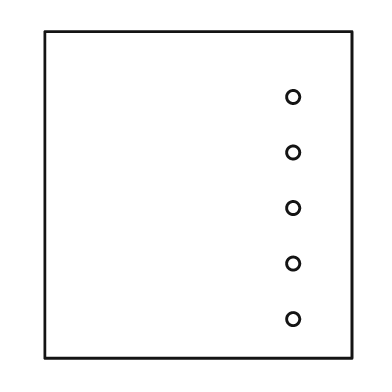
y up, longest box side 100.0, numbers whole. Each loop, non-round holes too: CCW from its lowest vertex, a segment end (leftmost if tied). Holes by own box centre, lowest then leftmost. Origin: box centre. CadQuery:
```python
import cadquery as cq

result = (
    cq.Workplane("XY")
    .moveTo(-47.0, -50.0)
    .lineTo(47.0, -50.0)
    .lineTo(47.0, 50.0)
    .lineTo(-47.0, 50.0)
    .close()
    .moveTo(29.0, -38.0)
    .circle(2.0)
    .moveTo(29.0, -21.0)
    .circle(2.0)
    .moveTo(29.0, -4.0)
    .circle(2.0)
    .moveTo(29.0, 13.0)
    .circle(2.0)
    .moveTo(29.0, 30.0)
    .circle(2.0)
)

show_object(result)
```